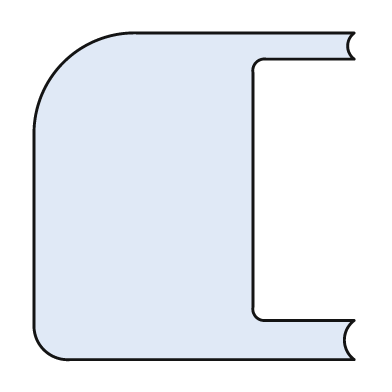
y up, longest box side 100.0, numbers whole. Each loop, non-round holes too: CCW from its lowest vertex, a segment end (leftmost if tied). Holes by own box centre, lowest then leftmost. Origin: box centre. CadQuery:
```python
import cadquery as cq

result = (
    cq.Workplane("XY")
    .moveTo(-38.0, -50.0)
    .lineTo(49.0, -50.0)
    .threePointArc((46.0, -44.0), (49.0, -38.0))
    .lineTo(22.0, -38.0)
    .threePointArc((19.0, -37.0), (18.0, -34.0))
    .lineTo(18.0, 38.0)
    .threePointArc((19.0, 41.0), (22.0, 42.0))
    .lineTo(49.0, 42.0)
    .threePointArc((47.0, 46.0), (49.0, 50.0))
    .lineTo(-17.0, 50.0)
    .threePointArc((-40.0, 41.0), (-49.0, 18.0))
    .lineTo(-49.0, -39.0)
    .threePointArc((-46.0, -47.0), (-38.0, -50.0))
    .close()
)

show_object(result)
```